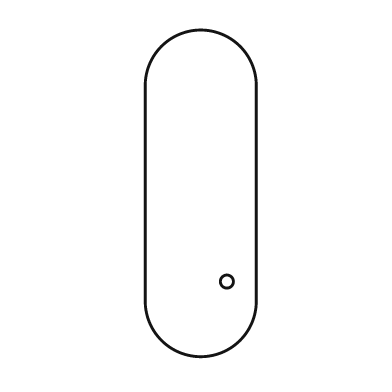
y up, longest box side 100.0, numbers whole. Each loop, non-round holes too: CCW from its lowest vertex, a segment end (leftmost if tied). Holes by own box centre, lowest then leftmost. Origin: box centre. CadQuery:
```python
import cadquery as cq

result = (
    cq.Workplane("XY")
    .moveTo(-17.0, -33.0)
    .threePointArc((0.0, -50.0), (17.0, -33.0))
    .lineTo(17.0, 33.0)
    .threePointArc((0.0, 50.0), (-17.0, 33.0))
    .close()
    .moveTo(8.0, -27.0)
    .circle(2.0)
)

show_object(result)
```